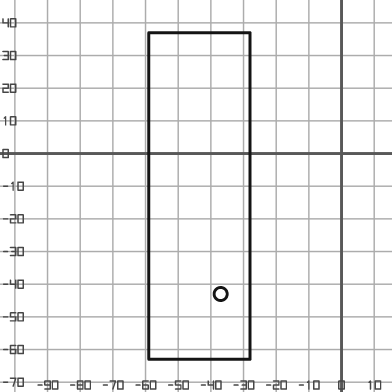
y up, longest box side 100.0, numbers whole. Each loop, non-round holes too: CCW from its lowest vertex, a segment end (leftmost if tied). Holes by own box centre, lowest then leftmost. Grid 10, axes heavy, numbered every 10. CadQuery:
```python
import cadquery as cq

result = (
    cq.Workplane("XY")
    .moveTo(-59.0, -63.0)
    .lineTo(-28.0, -63.0)
    .lineTo(-28.0, 37.0)
    .lineTo(-59.0, 37.0)
    .close()
    .moveTo(-37.0, -43.0)
    .circle(2.0)
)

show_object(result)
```